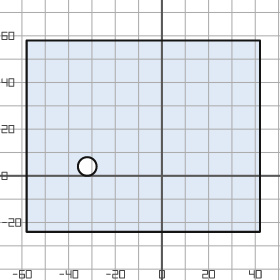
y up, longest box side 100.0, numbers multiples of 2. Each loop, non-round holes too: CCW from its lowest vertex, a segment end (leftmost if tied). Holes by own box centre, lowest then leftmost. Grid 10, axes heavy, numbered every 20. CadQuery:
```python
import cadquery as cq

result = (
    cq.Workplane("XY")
    .moveTo(-58.0, -24.0)
    .lineTo(42.0, -24.0)
    .lineTo(42.0, 58.0)
    .lineTo(-58.0, 58.0)
    .close()
    .moveTo(-32.0, 4.0)
    .circle(4.0)
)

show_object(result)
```